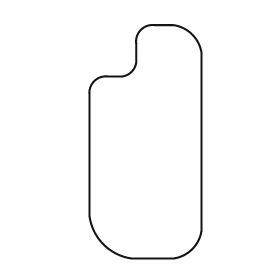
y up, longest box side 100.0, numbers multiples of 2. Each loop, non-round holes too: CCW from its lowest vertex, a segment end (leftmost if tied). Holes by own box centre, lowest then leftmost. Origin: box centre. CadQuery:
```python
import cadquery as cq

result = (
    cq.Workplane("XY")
    .moveTo(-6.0, -50.0)
    .lineTo(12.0, -50.0)
    .threePointArc((20.0, -46.0), (24.0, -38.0))
    .lineTo(24.0, 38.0)
    .threePointArc((20.0, 46.0), (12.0, 50.0))
    .lineTo(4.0, 50.0)
    .threePointArc((-2.0, 48.0), (-4.0, 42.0))
    .lineTo(-4.0, 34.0)
    .threePointArc((-6.0, 30.0), (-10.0, 28.0))
    .lineTo(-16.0, 28.0)
    .threePointArc((-22.0, 26.0), (-24.0, 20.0))
    .lineTo(-24.0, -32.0)
    .threePointArc((-18.0, -44.0), (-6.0, -50.0))
    .close()
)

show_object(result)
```